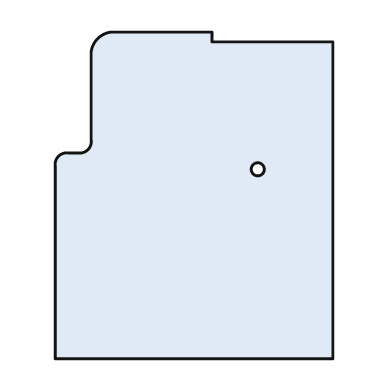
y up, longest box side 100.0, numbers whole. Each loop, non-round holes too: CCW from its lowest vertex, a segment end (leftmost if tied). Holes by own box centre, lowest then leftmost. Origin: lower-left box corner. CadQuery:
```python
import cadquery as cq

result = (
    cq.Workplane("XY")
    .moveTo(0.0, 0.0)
    .lineTo(85.0, 0.0)
    .lineTo(85.0, 97.0)
    .lineTo(48.0, 97.0)
    .lineTo(48.0, 100.0)
    .lineTo(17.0, 100.0)
    .threePointArc((13.0, 98.0), (11.0, 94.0))
    .lineTo(11.0, 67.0)
    .threePointArc((10.0, 64.0), (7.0, 63.0))
    .lineTo(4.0, 63.0)
    .threePointArc((1.0, 62.0), (0.0, 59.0))
    .close()
    .moveTo(62.0, 58.0)
    .circle(2.0)
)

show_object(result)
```